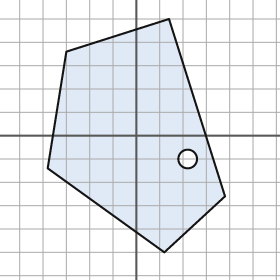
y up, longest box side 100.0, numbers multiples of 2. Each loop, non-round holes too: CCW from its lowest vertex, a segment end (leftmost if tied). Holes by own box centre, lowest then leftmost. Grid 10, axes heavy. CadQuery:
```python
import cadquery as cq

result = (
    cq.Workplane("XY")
    .moveTo(12.0, -50.0)
    .lineTo(38.0, -26.0)
    .lineTo(14.0, 50.0)
    .lineTo(-30.0, 36.0)
    .lineTo(-38.0, -14.0)
    .close()
    .moveTo(22.0, -10.0)
    .circle(4.0)
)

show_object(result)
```